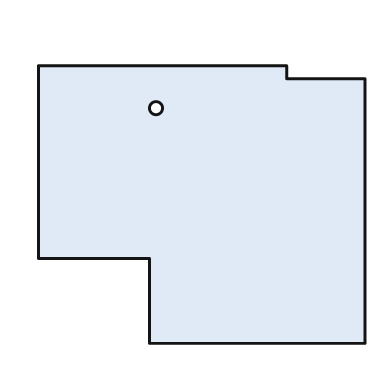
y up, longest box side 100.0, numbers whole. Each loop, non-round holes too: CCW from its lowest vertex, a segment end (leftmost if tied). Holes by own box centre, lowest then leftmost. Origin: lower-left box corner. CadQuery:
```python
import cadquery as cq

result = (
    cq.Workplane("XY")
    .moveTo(34.0, 0.0)
    .lineTo(100.0, 0.0)
    .lineTo(100.0, 81.0)
    .lineTo(76.0, 81.0)
    .lineTo(76.0, 85.0)
    .lineTo(0.0, 85.0)
    .lineTo(0.0, 26.0)
    .lineTo(34.0, 26.0)
    .close()
    .moveTo(36.0, 72.0)
    .circle(2.0)
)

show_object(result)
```